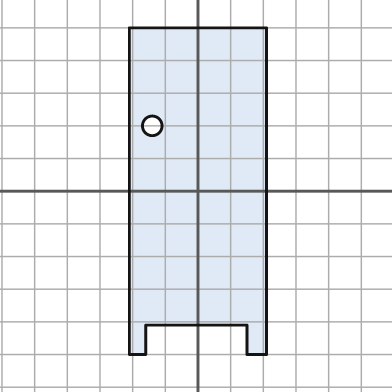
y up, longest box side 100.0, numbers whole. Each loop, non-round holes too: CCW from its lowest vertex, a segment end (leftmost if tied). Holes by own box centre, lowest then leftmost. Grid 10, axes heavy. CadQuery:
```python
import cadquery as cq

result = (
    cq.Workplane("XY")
    .moveTo(-21.0, -50.0)
    .lineTo(-16.0, -50.0)
    .lineTo(-16.0, -41.0)
    .lineTo(15.0, -41.0)
    .lineTo(15.0, -50.0)
    .lineTo(21.0, -50.0)
    .lineTo(21.0, 50.0)
    .lineTo(-21.0, 50.0)
    .close()
    .moveTo(-14.0, 20.0)
    .circle(3.0)
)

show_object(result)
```